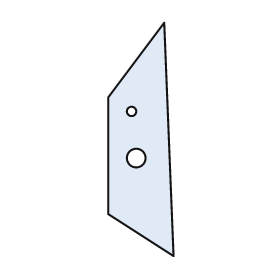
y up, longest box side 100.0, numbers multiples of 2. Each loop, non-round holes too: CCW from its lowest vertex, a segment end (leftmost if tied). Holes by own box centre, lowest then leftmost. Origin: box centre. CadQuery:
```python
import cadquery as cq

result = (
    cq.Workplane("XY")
    .moveTo(14.0, -50.0)
    .lineTo(10.0, 50.0)
    .lineTo(-14.0, 18.0)
    .lineTo(-14.0, -32.0)
    .close()
    .moveTo(-2.0, -8.0)
    .circle(4.0)
    .moveTo(-4.0, 12.0)
    .circle(2.0)
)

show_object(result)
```